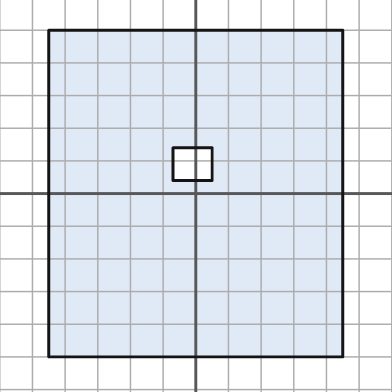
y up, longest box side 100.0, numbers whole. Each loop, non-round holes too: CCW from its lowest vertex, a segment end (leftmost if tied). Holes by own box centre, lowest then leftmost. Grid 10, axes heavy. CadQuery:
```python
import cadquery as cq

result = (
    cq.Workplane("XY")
    .moveTo(-45.0, -50.0)
    .lineTo(45.0, -50.0)
    .lineTo(45.0, 50.0)
    .lineTo(-45.0, 50.0)
    .close()
    .moveTo(-7.0, 4.0)
    .lineTo(5.0, 4.0)
    .lineTo(5.0, 14.0)
    .lineTo(-7.0, 14.0)
    .close()
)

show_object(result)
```